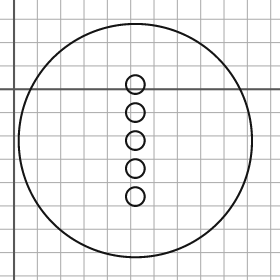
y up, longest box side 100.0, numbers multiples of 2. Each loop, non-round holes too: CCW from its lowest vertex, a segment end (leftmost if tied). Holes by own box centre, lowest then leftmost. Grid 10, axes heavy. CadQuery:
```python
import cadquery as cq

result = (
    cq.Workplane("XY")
    .moveTo(52.0, -22.0)
    .circle(50.0)
    .moveTo(52.0, -46.0)
    .circle(4.0)
    .moveTo(52.0, -34.0)
    .circle(4.0)
    .moveTo(52.0, -22.0)
    .circle(4.0)
    .moveTo(52.0, -10.0)
    .circle(4.0)
    .moveTo(52.0, 2.0)
    .circle(4.0)
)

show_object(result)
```